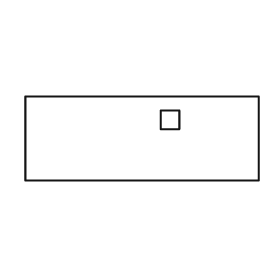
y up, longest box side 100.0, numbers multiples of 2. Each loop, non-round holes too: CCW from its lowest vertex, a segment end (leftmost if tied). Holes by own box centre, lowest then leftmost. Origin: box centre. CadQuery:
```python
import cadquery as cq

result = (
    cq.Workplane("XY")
    .moveTo(-50.0, -18.0)
    .lineTo(50.0, -18.0)
    .lineTo(50.0, 18.0)
    .lineTo(-50.0, 18.0)
    .close()
    .moveTo(8.0, 4.0)
    .lineTo(16.0, 4.0)
    .lineTo(16.0, 12.0)
    .lineTo(8.0, 12.0)
    .close()
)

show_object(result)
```